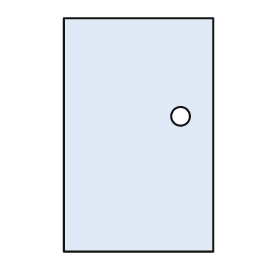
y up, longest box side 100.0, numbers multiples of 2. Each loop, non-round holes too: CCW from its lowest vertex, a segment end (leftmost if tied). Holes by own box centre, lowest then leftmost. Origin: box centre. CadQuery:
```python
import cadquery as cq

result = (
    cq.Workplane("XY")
    .moveTo(-32.0, -50.0)
    .lineTo(32.0, -50.0)
    .lineTo(32.0, 50.0)
    .lineTo(-32.0, 50.0)
    .close()
    .moveTo(18.0, 8.0)
    .circle(4.0)
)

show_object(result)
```